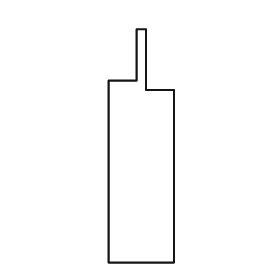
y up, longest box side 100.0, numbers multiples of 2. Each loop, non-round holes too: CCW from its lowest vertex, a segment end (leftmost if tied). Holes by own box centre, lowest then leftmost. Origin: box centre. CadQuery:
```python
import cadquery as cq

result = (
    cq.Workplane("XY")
    .moveTo(-14.0, -50.0)
    .lineTo(14.0, -50.0)
    .lineTo(14.0, 24.0)
    .lineTo(2.0, 24.0)
    .lineTo(2.0, 50.0)
    .lineTo(-2.0, 50.0)
    .lineTo(-2.0, 28.0)
    .lineTo(-14.0, 28.0)
    .close()
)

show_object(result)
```